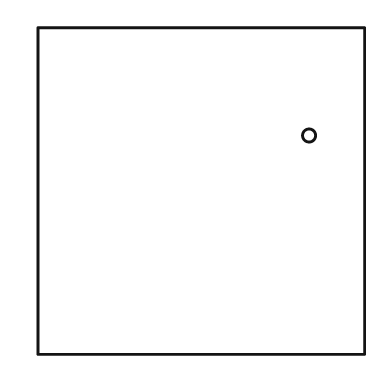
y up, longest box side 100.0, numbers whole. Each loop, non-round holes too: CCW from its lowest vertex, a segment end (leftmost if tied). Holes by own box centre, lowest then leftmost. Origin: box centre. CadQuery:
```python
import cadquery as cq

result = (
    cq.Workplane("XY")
    .moveTo(-50.0, -50.0)
    .lineTo(50.0, -50.0)
    .lineTo(50.0, 50.0)
    .lineTo(-50.0, 50.0)
    .close()
    .moveTo(33.0, 17.0)
    .circle(2.0)
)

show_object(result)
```